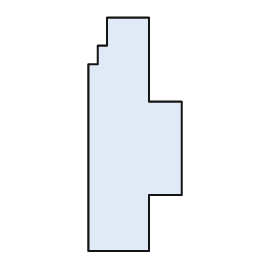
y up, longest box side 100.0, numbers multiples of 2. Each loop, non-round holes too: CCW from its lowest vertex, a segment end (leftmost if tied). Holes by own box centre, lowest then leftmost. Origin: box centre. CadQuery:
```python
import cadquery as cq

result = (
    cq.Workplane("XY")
    .moveTo(-20.0, -50.0)
    .lineTo(6.0, -50.0)
    .lineTo(6.0, -26.0)
    .lineTo(20.0, -26.0)
    .lineTo(20.0, 14.0)
    .lineTo(6.0, 14.0)
    .lineTo(6.0, 50.0)
    .lineTo(-12.0, 50.0)
    .lineTo(-12.0, 38.0)
    .lineTo(-16.0, 38.0)
    .lineTo(-16.0, 30.0)
    .lineTo(-20.0, 30.0)
    .close()
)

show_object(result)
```